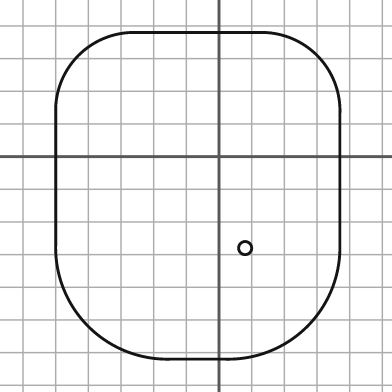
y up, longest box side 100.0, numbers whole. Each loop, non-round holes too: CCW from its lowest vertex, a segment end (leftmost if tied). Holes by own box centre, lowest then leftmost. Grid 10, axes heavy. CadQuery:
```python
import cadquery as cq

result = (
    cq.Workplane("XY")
    .moveTo(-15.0, -62.0)
    .lineTo(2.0, -62.0)
    .threePointArc((27.0, -52.0), (37.0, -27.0))
    .lineTo(37.0, 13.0)
    .threePointArc((30.0, 31.0), (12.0, 38.0))
    .lineTo(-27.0, 38.0)
    .threePointArc((-43.0, 31.0), (-50.0, 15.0))
    .lineTo(-50.0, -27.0)
    .threePointArc((-40.0, -52.0), (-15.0, -62.0))
    .close()
    .moveTo(8.0, -28.0)
    .circle(2.0)
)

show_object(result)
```